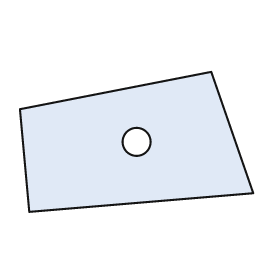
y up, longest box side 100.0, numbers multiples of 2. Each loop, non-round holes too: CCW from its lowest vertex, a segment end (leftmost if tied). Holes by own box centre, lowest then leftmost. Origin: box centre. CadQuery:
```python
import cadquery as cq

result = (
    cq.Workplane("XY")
    .moveTo(-46.0, -30.0)
    .lineTo(50.0, -22.0)
    .lineTo(32.0, 30.0)
    .lineTo(-50.0, 14.0)
    .close()
    .moveTo(0.0, 0.0)
    .circle(6.0)
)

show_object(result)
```